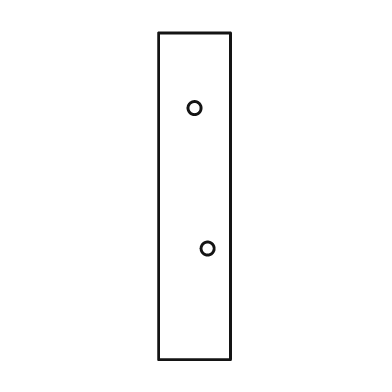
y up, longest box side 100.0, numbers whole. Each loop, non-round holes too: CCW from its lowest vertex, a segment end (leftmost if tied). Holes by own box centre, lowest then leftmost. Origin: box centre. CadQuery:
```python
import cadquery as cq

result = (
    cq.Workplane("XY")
    .moveTo(-11.0, -50.0)
    .lineTo(11.0, -50.0)
    .lineTo(11.0, 50.0)
    .lineTo(-11.0, 50.0)
    .close()
    .moveTo(4.0, -16.0)
    .circle(2.0)
    .moveTo(0.0, 27.0)
    .circle(2.0)
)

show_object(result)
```